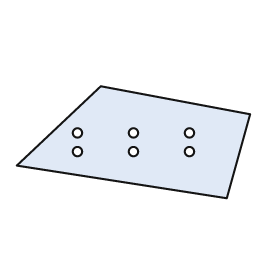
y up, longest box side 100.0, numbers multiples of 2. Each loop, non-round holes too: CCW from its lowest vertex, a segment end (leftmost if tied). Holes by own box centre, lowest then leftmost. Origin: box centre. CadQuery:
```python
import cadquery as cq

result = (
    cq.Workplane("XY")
    .moveTo(40.0, -24.0)
    .lineTo(50.0, 12.0)
    .lineTo(-14.0, 24.0)
    .lineTo(-50.0, -10.0)
    .close()
    .moveTo(-24.0, -4.0)
    .circle(2.0)
    .moveTo(0.0, -4.0)
    .circle(2.0)
    .moveTo(24.0, -4.0)
    .circle(2.0)
    .moveTo(-24.0, 4.0)
    .circle(2.0)
    .moveTo(0.0, 4.0)
    .circle(2.0)
    .moveTo(24.0, 4.0)
    .circle(2.0)
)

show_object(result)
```